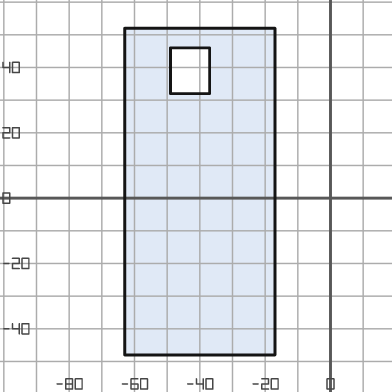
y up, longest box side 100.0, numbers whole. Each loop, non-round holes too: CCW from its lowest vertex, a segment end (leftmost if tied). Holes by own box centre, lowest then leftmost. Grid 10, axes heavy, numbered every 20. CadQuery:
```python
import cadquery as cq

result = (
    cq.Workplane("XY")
    .moveTo(-63.0, -48.0)
    .lineTo(-17.0, -48.0)
    .lineTo(-17.0, 52.0)
    .lineTo(-63.0, 52.0)
    .close()
    .moveTo(-49.0, 32.0)
    .lineTo(-37.0, 32.0)
    .lineTo(-37.0, 46.0)
    .lineTo(-49.0, 46.0)
    .close()
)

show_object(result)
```